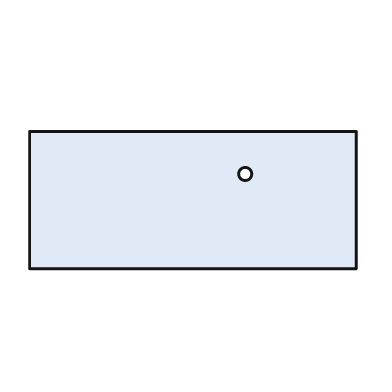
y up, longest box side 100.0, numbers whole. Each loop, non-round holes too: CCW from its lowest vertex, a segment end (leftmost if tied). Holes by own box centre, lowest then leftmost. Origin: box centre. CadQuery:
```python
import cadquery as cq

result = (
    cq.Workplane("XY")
    .moveTo(-50.0, -21.0)
    .lineTo(50.0, -21.0)
    .lineTo(50.0, 21.0)
    .lineTo(-50.0, 21.0)
    .close()
    .moveTo(16.0, 8.0)
    .circle(2.0)
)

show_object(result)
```